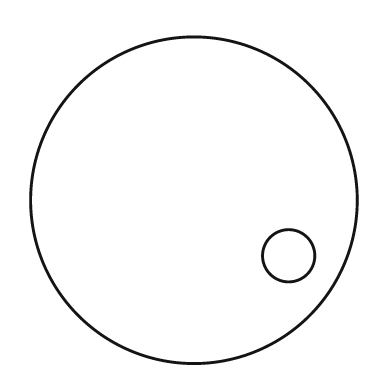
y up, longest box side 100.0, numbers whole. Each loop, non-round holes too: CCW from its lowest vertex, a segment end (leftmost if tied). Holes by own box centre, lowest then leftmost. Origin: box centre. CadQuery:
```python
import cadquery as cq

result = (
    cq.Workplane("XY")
    .moveTo(0.0, 0.0)
    .circle(50.0)
    .moveTo(29.0, -17.0)
    .circle(8.0)
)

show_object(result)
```